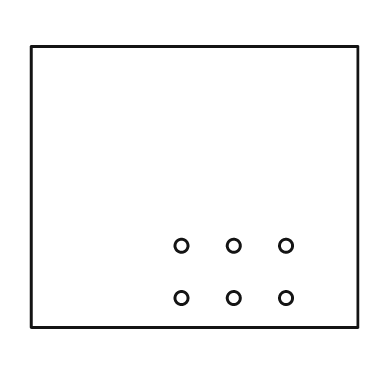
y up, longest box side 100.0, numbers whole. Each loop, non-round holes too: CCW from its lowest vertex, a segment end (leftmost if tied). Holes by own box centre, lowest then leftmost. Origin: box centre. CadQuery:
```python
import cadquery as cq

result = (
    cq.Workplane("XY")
    .moveTo(-50.0, -43.0)
    .lineTo(50.0, -43.0)
    .lineTo(50.0, 43.0)
    .lineTo(-50.0, 43.0)
    .close()
    .moveTo(-4.0, -34.0)
    .circle(2.0)
    .moveTo(12.0, -34.0)
    .circle(2.0)
    .moveTo(28.0, -34.0)
    .circle(2.0)
    .moveTo(-4.0, -18.0)
    .circle(2.0)
    .moveTo(12.0, -18.0)
    .circle(2.0)
    .moveTo(28.0, -18.0)
    .circle(2.0)
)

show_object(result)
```